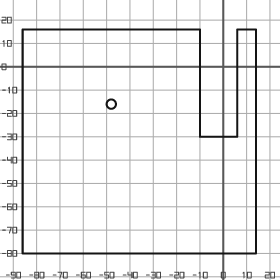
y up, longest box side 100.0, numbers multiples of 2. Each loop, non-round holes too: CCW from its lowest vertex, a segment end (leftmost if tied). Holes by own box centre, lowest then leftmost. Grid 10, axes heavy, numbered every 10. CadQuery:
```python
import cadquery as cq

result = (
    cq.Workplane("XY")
    .moveTo(-86.0, -80.0)
    .lineTo(14.0, -80.0)
    .lineTo(14.0, 16.0)
    .lineTo(6.0, 16.0)
    .lineTo(6.0, -30.0)
    .lineTo(-10.0, -30.0)
    .lineTo(-10.0, 16.0)
    .lineTo(-86.0, 16.0)
    .close()
    .moveTo(-48.0, -16.0)
    .circle(2.0)
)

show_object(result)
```